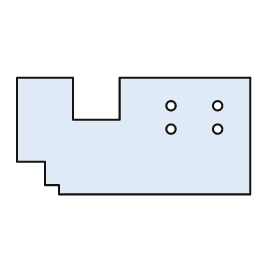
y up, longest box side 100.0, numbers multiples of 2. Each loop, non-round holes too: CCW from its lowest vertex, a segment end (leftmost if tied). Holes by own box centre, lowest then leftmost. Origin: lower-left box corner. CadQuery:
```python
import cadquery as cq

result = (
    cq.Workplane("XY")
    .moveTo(18.0, 0.0)
    .lineTo(100.0, 0.0)
    .lineTo(100.0, 50.0)
    .lineTo(44.0, 50.0)
    .lineTo(44.0, 32.0)
    .lineTo(24.0, 32.0)
    .lineTo(24.0, 50.0)
    .lineTo(0.0, 50.0)
    .lineTo(0.0, 14.0)
    .lineTo(12.0, 14.0)
    .lineTo(12.0, 4.0)
    .lineTo(18.0, 4.0)
    .close()
    .moveTo(66.0, 28.0)
    .circle(2.0)
    .moveTo(86.0, 28.0)
    .circle(2.0)
    .moveTo(66.0, 38.0)
    .circle(2.0)
    .moveTo(86.0, 38.0)
    .circle(2.0)
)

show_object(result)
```